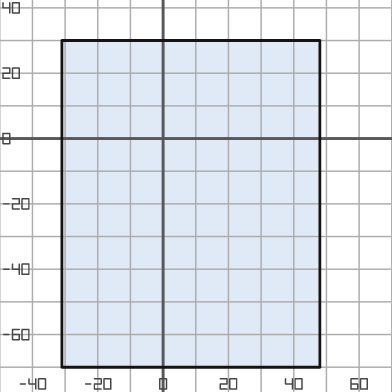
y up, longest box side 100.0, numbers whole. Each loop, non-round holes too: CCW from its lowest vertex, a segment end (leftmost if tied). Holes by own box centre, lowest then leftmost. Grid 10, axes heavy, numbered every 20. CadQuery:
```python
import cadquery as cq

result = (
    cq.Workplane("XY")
    .moveTo(-31.0, -70.0)
    .lineTo(48.0, -70.0)
    .lineTo(48.0, 30.0)
    .lineTo(-31.0, 30.0)
    .close()
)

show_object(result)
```